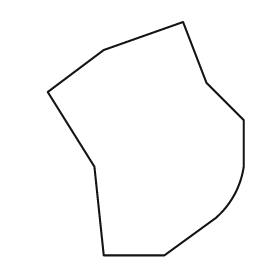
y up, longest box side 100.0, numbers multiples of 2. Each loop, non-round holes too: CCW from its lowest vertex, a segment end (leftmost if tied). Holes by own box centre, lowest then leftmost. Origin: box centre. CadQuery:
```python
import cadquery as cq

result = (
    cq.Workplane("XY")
    .moveTo(-18.0, -50.0)
    .lineTo(8.0, -50.0)
    .lineTo(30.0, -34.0)
    .threePointArc((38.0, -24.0), (42.0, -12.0))
    .lineTo(42.0, 8.0)
    .lineTo(26.0, 24.0)
    .lineTo(16.0, 50.0)
    .lineTo(-18.0, 38.0)
    .lineTo(-42.0, 20.0)
    .lineTo(-22.0, -12.0)
    .close()
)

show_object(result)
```